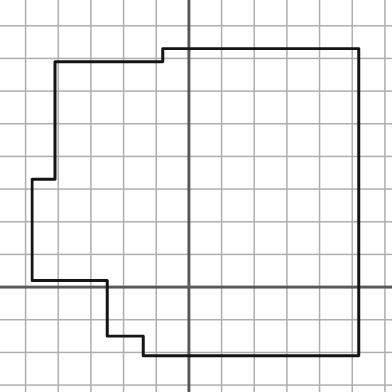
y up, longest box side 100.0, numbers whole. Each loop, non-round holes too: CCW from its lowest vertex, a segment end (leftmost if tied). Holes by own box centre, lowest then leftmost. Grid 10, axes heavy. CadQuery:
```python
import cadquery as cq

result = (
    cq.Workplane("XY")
    .moveTo(-14.0, -21.0)
    .lineTo(52.0, -21.0)
    .lineTo(52.0, 73.0)
    .lineTo(-8.0, 73.0)
    .lineTo(-8.0, 69.0)
    .lineTo(-41.0, 69.0)
    .lineTo(-41.0, 33.0)
    .lineTo(-48.0, 33.0)
    .lineTo(-48.0, 2.0)
    .lineTo(-25.0, 2.0)
    .lineTo(-25.0, -15.0)
    .lineTo(-14.0, -15.0)
    .close()
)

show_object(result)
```